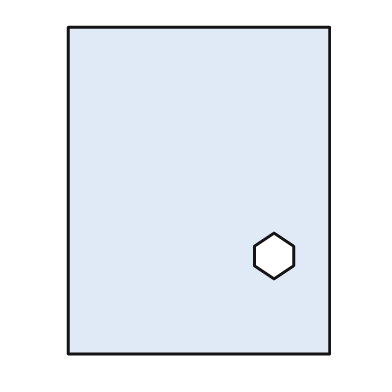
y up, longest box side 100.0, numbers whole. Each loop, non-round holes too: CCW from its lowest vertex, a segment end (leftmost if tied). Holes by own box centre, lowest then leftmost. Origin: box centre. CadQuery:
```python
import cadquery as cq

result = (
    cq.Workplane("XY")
    .moveTo(-40.0, -50.0)
    .lineTo(40.0, -50.0)
    .lineTo(40.0, 50.0)
    .lineTo(-40.0, 50.0)
    .close()
    .moveTo(23.0, -27.0)
    .lineTo(29.0, -23.0)
    .lineTo(29.0, -17.0)
    .lineTo(23.0, -13.0)
    .lineTo(17.0, -17.0)
    .lineTo(17.0, -23.0)
    .close()
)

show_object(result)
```